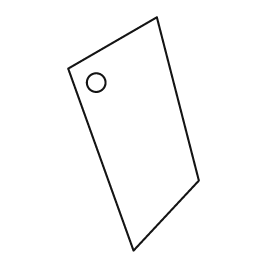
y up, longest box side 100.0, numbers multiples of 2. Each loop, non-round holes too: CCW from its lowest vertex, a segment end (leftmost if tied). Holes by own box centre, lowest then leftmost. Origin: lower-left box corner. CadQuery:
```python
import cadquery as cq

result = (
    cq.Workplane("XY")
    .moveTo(28.0, 0.0)
    .lineTo(56.0, 30.0)
    .lineTo(38.0, 100.0)
    .lineTo(0.0, 78.0)
    .close()
    .moveTo(12.0, 72.0)
    .circle(4.0)
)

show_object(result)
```